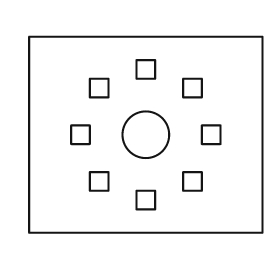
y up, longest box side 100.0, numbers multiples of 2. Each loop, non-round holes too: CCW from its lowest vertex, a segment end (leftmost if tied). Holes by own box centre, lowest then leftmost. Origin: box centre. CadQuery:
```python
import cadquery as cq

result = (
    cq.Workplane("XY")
    .moveTo(-50.0, -42.0)
    .lineTo(50.0, -42.0)
    .lineTo(50.0, 42.0)
    .lineTo(-50.0, 42.0)
    .close()
    .moveTo(-4.0, -32.0)
    .lineTo(4.0, -32.0)
    .lineTo(4.0, -24.0)
    .lineTo(-4.0, -24.0)
    .close()
    .moveTo(-24.0, -24.0)
    .lineTo(-16.0, -24.0)
    .lineTo(-16.0, -16.0)
    .lineTo(-24.0, -16.0)
    .close()
    .moveTo(16.0, -24.0)
    .lineTo(24.0, -24.0)
    .lineTo(24.0, -16.0)
    .lineTo(16.0, -16.0)
    .close()
    .moveTo(-32.0, -4.0)
    .lineTo(-24.0, -4.0)
    .lineTo(-24.0, 4.0)
    .lineTo(-32.0, 4.0)
    .close()
    .moveTo(0.0, 0.0)
    .circle(10.0)
    .moveTo(24.0, -4.0)
    .lineTo(32.0, -4.0)
    .lineTo(32.0, 4.0)
    .lineTo(24.0, 4.0)
    .close()
    .moveTo(-24.0, 16.0)
    .lineTo(-16.0, 16.0)
    .lineTo(-16.0, 24.0)
    .lineTo(-24.0, 24.0)
    .close()
    .moveTo(16.0, 16.0)
    .lineTo(24.0, 16.0)
    .lineTo(24.0, 24.0)
    .lineTo(16.0, 24.0)
    .close()
    .moveTo(-4.0, 24.0)
    .lineTo(4.0, 24.0)
    .lineTo(4.0, 32.0)
    .lineTo(-4.0, 32.0)
    .close()
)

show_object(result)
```